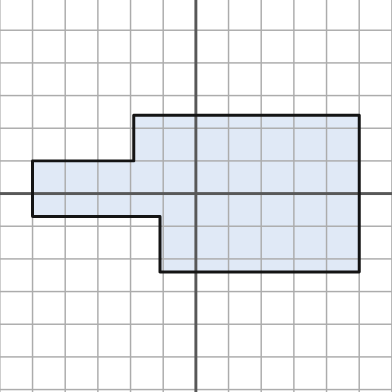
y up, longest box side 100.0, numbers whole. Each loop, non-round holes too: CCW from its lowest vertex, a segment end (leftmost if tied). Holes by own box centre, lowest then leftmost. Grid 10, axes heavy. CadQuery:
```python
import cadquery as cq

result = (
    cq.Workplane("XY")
    .moveTo(-11.0, -24.0)
    .lineTo(50.0, -24.0)
    .lineTo(50.0, 24.0)
    .lineTo(-19.0, 24.0)
    .lineTo(-19.0, 10.0)
    .lineTo(-50.0, 10.0)
    .lineTo(-50.0, -7.0)
    .lineTo(-11.0, -7.0)
    .close()
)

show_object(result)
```